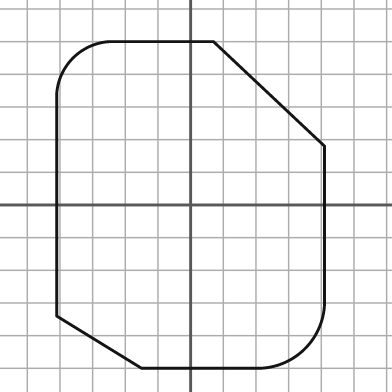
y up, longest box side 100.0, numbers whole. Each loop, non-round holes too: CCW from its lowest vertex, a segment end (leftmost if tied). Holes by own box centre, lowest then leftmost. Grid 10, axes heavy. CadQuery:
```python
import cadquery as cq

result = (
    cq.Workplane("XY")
    .moveTo(-15.0, -50.0)
    .lineTo(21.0, -50.0)
    .threePointArc((35.0, -44.0), (41.0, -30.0))
    .lineTo(41.0, 18.0)
    .lineTo(7.0, 50.0)
    .lineTo(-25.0, 50.0)
    .threePointArc((-36.0, 45.0), (-41.0, 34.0))
    .lineTo(-41.0, -34.0)
    .close()
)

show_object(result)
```